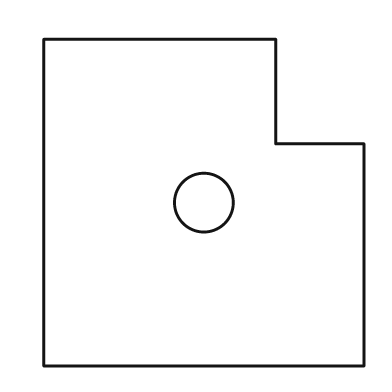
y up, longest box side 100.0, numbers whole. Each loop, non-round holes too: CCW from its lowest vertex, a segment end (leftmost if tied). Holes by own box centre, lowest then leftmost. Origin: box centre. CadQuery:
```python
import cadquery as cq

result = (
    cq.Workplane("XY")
    .moveTo(-49.0, -50.0)
    .lineTo(49.0, -50.0)
    .lineTo(49.0, 18.0)
    .lineTo(22.0, 18.0)
    .lineTo(22.0, 50.0)
    .lineTo(-49.0, 50.0)
    .close()
    .moveTo(0.0, 0.0)
    .circle(9.0)
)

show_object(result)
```